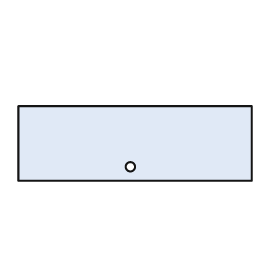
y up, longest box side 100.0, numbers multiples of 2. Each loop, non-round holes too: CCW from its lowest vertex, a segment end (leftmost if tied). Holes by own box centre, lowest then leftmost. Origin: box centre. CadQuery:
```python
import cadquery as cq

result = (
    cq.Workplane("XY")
    .moveTo(-50.0, -16.0)
    .lineTo(50.0, -16.0)
    .lineTo(50.0, 16.0)
    .lineTo(-50.0, 16.0)
    .close()
    .moveTo(-2.0, -10.0)
    .circle(2.0)
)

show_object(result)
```